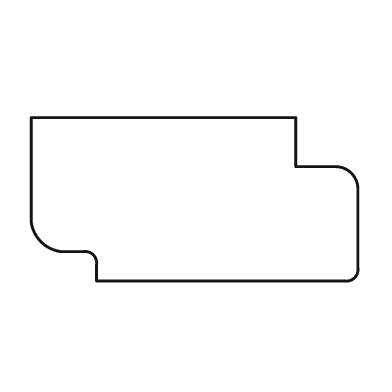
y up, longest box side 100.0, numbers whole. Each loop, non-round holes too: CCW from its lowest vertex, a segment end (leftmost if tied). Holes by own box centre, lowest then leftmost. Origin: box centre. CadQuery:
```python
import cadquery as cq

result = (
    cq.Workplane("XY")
    .moveTo(-30.0, -25.0)
    .lineTo(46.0, -25.0)
    .threePointArc((49.0, -24.0), (50.0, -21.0))
    .lineTo(50.0, 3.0)
    .threePointArc((48.0, 8.0), (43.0, 10.0))
    .lineTo(31.0, 10.0)
    .lineTo(31.0, 25.0)
    .lineTo(-50.0, 25.0)
    .lineTo(-50.0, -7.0)
    .threePointArc((-47.0, -13.0), (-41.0, -16.0))
    .lineTo(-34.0, -16.0)
    .threePointArc((-31.0, -17.0), (-30.0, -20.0))
    .close()
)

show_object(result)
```